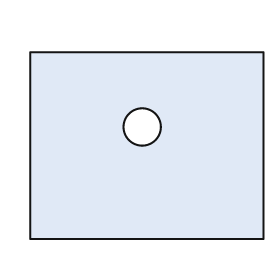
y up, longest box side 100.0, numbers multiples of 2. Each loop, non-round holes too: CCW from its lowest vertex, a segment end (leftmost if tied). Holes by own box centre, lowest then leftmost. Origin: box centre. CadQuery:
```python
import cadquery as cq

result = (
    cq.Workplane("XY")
    .moveTo(-50.0, -40.0)
    .lineTo(50.0, -40.0)
    .lineTo(50.0, 40.0)
    .lineTo(-50.0, 40.0)
    .close()
    .moveTo(-2.0, 8.0)
    .circle(8.0)
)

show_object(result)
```